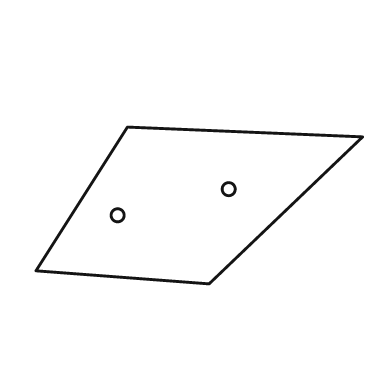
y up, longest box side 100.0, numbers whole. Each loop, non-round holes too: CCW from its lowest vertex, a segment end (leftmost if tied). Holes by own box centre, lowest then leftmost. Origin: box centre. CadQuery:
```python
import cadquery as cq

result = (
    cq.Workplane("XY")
    .moveTo(3.0, -24.0)
    .lineTo(50.0, 21.0)
    .lineTo(-22.0, 24.0)
    .lineTo(-50.0, -20.0)
    .close()
    .moveTo(-25.0, -3.0)
    .circle(2.0)
    .moveTo(9.0, 5.0)
    .circle(2.0)
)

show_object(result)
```